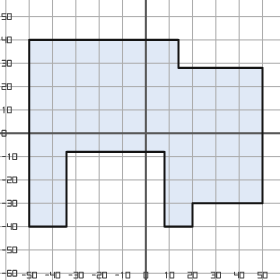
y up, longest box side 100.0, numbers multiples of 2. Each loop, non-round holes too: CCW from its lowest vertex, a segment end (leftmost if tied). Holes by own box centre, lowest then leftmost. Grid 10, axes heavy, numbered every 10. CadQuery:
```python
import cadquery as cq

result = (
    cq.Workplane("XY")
    .moveTo(-50.0, -40.0)
    .lineTo(-34.0, -40.0)
    .lineTo(-34.0, -8.0)
    .lineTo(8.0, -8.0)
    .lineTo(8.0, -40.0)
    .lineTo(20.0, -40.0)
    .lineTo(20.0, -30.0)
    .lineTo(50.0, -30.0)
    .lineTo(50.0, 28.0)
    .lineTo(14.0, 28.0)
    .lineTo(14.0, 40.0)
    .lineTo(-50.0, 40.0)
    .close()
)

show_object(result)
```